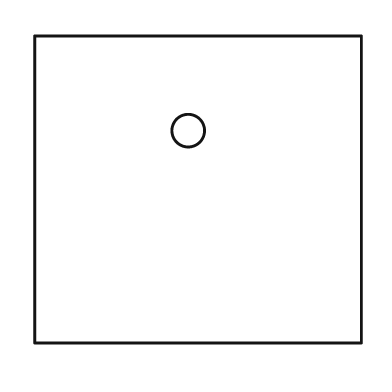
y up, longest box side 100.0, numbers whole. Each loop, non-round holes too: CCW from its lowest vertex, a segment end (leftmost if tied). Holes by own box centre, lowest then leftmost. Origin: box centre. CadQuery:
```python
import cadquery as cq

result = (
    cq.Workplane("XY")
    .moveTo(-50.0, -47.0)
    .lineTo(50.0, -47.0)
    .lineTo(50.0, 47.0)
    .lineTo(-50.0, 47.0)
    .close()
    .moveTo(-3.0, 18.0)
    .circle(5.0)
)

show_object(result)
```